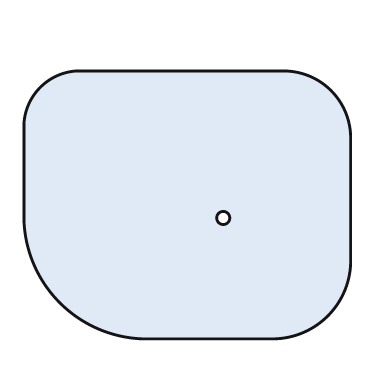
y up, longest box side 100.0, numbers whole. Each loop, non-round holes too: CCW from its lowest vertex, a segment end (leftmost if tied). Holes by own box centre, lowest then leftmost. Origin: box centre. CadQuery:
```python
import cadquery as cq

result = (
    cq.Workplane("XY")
    .moveTo(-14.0, -41.0)
    .lineTo(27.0, -41.0)
    .threePointArc((43.0, -34.0), (50.0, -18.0))
    .lineTo(50.0, 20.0)
    .threePointArc((44.0, 35.0), (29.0, 41.0))
    .lineTo(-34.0, 41.0)
    .threePointArc((-45.0, 36.0), (-50.0, 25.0))
    .lineTo(-50.0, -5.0)
    .threePointArc((-39.0, -30.0), (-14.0, -41.0))
    .close()
    .moveTo(11.0, -4.0)
    .circle(2.0)
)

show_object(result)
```